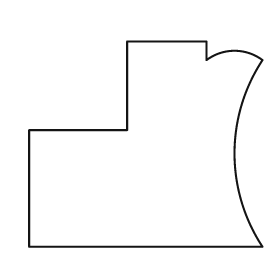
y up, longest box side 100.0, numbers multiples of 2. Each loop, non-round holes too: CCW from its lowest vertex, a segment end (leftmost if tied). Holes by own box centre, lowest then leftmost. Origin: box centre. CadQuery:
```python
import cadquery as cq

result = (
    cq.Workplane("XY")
    .moveTo(-50.0, -44.0)
    .lineTo(50.0, -44.0)
    .threePointArc((38.0, -4.0), (50.0, 36.0))
    .threePointArc((38.0, 40.0), (26.0, 36.0))
    .lineTo(26.0, 44.0)
    .lineTo(-8.0, 44.0)
    .lineTo(-8.0, 6.0)
    .lineTo(-50.0, 6.0)
    .close()
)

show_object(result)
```